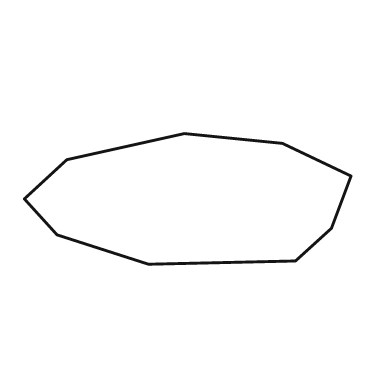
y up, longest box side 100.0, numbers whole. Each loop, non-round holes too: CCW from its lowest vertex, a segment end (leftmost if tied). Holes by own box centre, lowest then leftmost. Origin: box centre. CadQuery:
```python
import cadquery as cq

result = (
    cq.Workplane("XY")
    .moveTo(-12.0, -20.0)
    .lineTo(33.0, -19.0)
    .lineTo(44.0, -9.0)
    .lineTo(50.0, 7.0)
    .lineTo(29.0, 17.0)
    .lineTo(-1.0, 20.0)
    .lineTo(-37.0, 12.0)
    .lineTo(-50.0, 0.0)
    .lineTo(-40.0, -11.0)
    .close()
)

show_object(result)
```